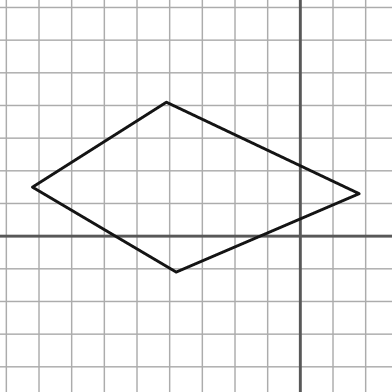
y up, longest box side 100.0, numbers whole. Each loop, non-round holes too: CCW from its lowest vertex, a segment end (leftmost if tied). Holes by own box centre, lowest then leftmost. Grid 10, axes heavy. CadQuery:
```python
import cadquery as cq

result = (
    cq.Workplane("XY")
    .moveTo(-38.0, -11.0)
    .lineTo(18.0, 13.0)
    .lineTo(-41.0, 41.0)
    .lineTo(-82.0, 15.0)
    .close()
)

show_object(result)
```